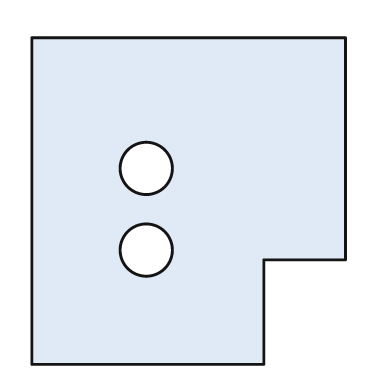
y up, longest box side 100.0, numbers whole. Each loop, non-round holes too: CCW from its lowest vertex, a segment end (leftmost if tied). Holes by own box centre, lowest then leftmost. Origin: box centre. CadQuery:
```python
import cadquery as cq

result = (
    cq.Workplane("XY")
    .moveTo(-48.0, -50.0)
    .lineTo(23.0, -50.0)
    .lineTo(23.0, -18.0)
    .lineTo(48.0, -18.0)
    .lineTo(48.0, 50.0)
    .lineTo(-48.0, 50.0)
    .close()
    .moveTo(-13.0, -15.0)
    .circle(8.0)
    .moveTo(-13.0, 10.0)
    .circle(8.0)
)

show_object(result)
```